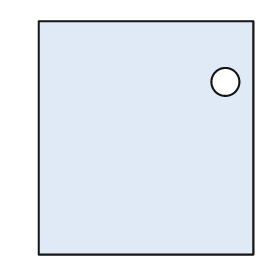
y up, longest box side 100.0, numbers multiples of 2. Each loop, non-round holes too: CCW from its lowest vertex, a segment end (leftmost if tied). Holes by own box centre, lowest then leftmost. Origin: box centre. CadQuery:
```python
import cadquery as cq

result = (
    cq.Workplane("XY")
    .moveTo(-46.0, -50.0)
    .lineTo(46.0, -50.0)
    .lineTo(46.0, 50.0)
    .lineTo(-46.0, 50.0)
    .close()
    .moveTo(34.0, 24.0)
    .circle(6.0)
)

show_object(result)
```